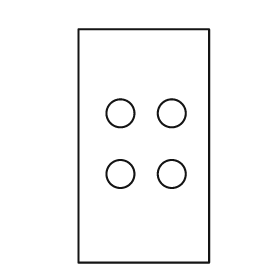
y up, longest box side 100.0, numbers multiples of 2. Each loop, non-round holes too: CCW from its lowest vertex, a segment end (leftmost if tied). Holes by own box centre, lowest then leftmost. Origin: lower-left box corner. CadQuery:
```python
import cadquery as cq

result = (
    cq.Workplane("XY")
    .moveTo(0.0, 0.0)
    .lineTo(56.0, 0.0)
    .lineTo(56.0, 100.0)
    .lineTo(0.0, 100.0)
    .close()
    .moveTo(18.0, 38.0)
    .circle(6.0)
    .moveTo(40.0, 38.0)
    .circle(6.0)
    .moveTo(18.0, 64.0)
    .circle(6.0)
    .moveTo(40.0, 64.0)
    .circle(6.0)
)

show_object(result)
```